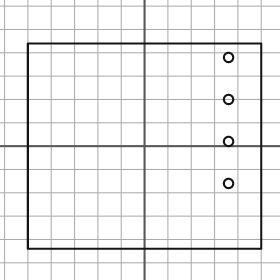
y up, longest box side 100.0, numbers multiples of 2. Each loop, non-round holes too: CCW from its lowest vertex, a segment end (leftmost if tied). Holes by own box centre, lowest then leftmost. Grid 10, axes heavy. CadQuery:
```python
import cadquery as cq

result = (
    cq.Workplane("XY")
    .moveTo(-50.0, -44.0)
    .lineTo(50.0, -44.0)
    .lineTo(50.0, 44.0)
    .lineTo(-50.0, 44.0)
    .close()
    .moveTo(36.0, -16.0)
    .circle(2.0)
    .moveTo(36.0, 2.0)
    .circle(2.0)
    .moveTo(36.0, 20.0)
    .circle(2.0)
    .moveTo(36.0, 38.0)
    .circle(2.0)
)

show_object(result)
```